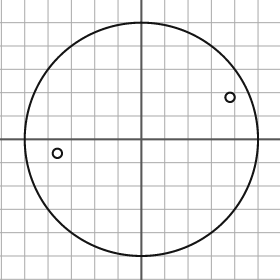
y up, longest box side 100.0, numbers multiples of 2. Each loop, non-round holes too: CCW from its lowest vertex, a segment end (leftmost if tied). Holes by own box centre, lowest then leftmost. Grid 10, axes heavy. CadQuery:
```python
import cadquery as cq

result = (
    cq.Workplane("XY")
    .moveTo(0.0, 0.0)
    .circle(50.0)
    .moveTo(-36.0, -6.0)
    .circle(2.0)
    .moveTo(38.0, 18.0)
    .circle(2.0)
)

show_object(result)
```